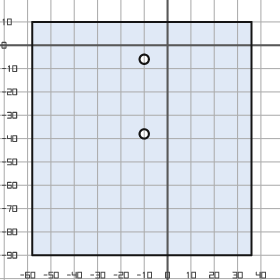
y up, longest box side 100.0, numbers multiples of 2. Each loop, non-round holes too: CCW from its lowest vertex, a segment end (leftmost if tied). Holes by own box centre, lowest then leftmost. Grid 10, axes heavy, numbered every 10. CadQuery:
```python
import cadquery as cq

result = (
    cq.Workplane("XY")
    .moveTo(-58.0, -90.0)
    .lineTo(36.0, -90.0)
    .lineTo(36.0, 10.0)
    .lineTo(-58.0, 10.0)
    .close()
    .moveTo(-10.0, -38.0)
    .circle(2.0)
    .moveTo(-10.0, -6.0)
    .circle(2.0)
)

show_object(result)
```